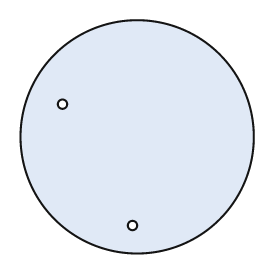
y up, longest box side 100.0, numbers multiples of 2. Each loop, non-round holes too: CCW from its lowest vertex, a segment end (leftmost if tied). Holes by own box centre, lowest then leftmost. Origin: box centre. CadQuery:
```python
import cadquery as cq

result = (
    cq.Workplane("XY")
    .moveTo(0.0, 0.0)
    .circle(50.0)
    .moveTo(-2.0, -38.0)
    .circle(2.0)
    .moveTo(-32.0, 14.0)
    .circle(2.0)
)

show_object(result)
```